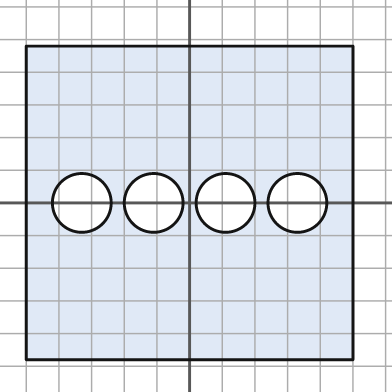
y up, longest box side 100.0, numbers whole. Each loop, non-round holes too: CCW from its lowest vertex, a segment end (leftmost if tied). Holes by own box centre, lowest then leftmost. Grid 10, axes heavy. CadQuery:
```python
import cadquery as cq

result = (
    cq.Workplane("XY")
    .moveTo(-50.0, -48.0)
    .lineTo(50.0, -48.0)
    .lineTo(50.0, 48.0)
    .lineTo(-50.0, 48.0)
    .close()
    .moveTo(-33.0, 0.0)
    .circle(9.0)
    .moveTo(-11.0, 0.0)
    .circle(9.0)
    .moveTo(11.0, 0.0)
    .circle(9.0)
    .moveTo(33.0, 0.0)
    .circle(9.0)
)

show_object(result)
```